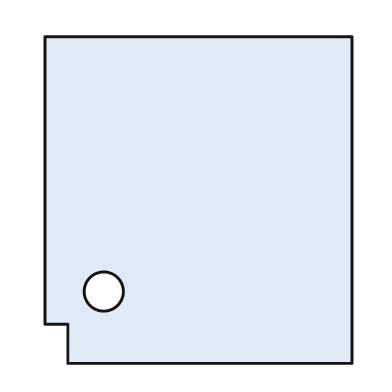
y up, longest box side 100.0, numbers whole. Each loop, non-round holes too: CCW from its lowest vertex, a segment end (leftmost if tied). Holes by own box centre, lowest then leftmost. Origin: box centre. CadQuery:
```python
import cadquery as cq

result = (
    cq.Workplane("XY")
    .moveTo(-40.0, -50.0)
    .lineTo(47.0, -50.0)
    .lineTo(47.0, 50.0)
    .lineTo(-47.0, 50.0)
    .lineTo(-47.0, -38.0)
    .lineTo(-40.0, -38.0)
    .close()
    .moveTo(-29.0, -28.0)
    .circle(6.0)
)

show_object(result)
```